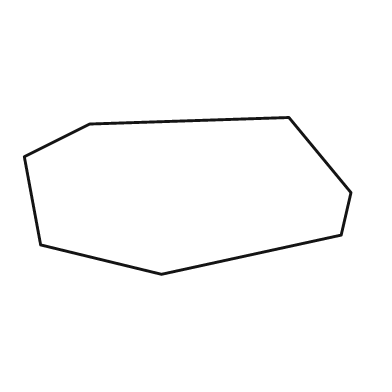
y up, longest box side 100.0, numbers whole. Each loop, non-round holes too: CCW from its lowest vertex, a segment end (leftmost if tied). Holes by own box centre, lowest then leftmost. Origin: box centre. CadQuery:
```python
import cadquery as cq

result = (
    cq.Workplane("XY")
    .moveTo(-8.0, -24.0)
    .lineTo(47.0, -12.0)
    .lineTo(50.0, 1.0)
    .lineTo(31.0, 24.0)
    .lineTo(-30.0, 22.0)
    .lineTo(-50.0, 12.0)
    .lineTo(-45.0, -15.0)
    .close()
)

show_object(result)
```